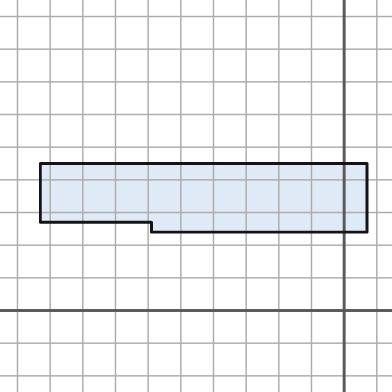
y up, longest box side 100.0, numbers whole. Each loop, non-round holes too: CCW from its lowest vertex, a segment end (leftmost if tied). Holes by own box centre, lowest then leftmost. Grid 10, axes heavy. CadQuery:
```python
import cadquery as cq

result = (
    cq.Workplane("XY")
    .moveTo(-59.0, 24.0)
    .lineTo(7.0, 24.0)
    .lineTo(7.0, 45.0)
    .lineTo(-93.0, 45.0)
    .lineTo(-93.0, 27.0)
    .lineTo(-59.0, 27.0)
    .close()
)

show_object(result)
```